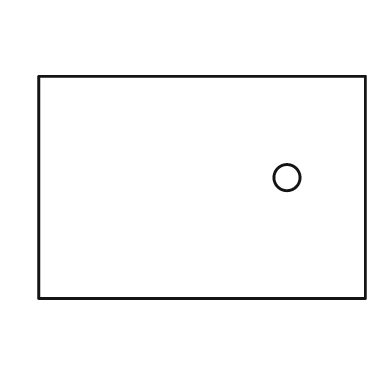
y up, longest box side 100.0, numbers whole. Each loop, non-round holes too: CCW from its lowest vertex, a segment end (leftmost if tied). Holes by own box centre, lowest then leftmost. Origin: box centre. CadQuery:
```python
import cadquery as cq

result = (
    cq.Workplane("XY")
    .moveTo(-50.0, -34.0)
    .lineTo(50.0, -34.0)
    .lineTo(50.0, 34.0)
    .lineTo(-50.0, 34.0)
    .close()
    .moveTo(26.0, 3.0)
    .circle(4.0)
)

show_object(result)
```